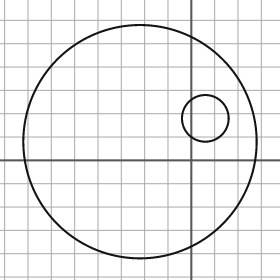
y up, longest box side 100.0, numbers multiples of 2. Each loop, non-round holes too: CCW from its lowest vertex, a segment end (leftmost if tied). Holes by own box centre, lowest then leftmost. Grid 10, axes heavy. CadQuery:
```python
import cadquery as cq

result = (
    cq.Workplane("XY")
    .moveTo(-22.0, 8.0)
    .circle(50.0)
    .moveTo(6.0, 18.0)
    .circle(10.0)
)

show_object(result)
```